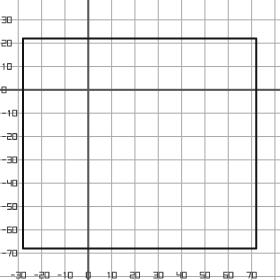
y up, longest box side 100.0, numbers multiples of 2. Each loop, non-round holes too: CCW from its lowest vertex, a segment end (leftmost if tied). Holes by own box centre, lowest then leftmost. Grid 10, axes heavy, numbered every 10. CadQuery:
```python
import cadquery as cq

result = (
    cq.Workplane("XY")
    .moveTo(-28.0, -68.0)
    .lineTo(72.0, -68.0)
    .lineTo(72.0, 22.0)
    .lineTo(-28.0, 22.0)
    .close()
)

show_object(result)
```